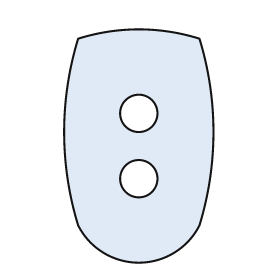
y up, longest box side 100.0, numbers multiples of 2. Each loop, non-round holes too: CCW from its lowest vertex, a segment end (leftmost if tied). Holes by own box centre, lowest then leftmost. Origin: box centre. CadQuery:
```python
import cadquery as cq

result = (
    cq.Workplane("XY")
    .moveTo(-26.0, -34.0)
    .threePointArc((0.0, -50.0), (26.0, -34.0))
    .threePointArc((32.0, 6.0), (26.0, 46.0))
    .threePointArc((0.0, 50.0), (-26.0, 46.0))
    .threePointArc((-32.0, 6.0), (-26.0, -34.0))
    .close()
    .moveTo(0.0, -14.0)
    .circle(8.0)
    .moveTo(0.0, 14.0)
    .circle(8.0)
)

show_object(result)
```